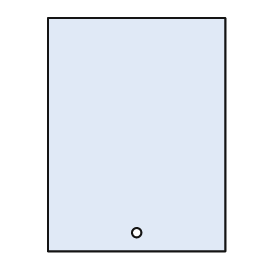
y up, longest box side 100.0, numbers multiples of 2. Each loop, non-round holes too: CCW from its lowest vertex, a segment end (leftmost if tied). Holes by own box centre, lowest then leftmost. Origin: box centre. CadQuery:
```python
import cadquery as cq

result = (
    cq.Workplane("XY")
    .moveTo(-38.0, -50.0)
    .lineTo(38.0, -50.0)
    .lineTo(38.0, 50.0)
    .lineTo(-38.0, 50.0)
    .close()
    .moveTo(0.0, -42.0)
    .circle(2.0)
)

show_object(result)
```